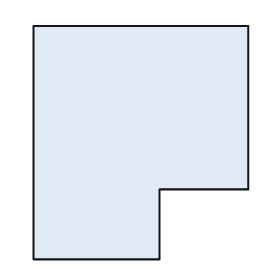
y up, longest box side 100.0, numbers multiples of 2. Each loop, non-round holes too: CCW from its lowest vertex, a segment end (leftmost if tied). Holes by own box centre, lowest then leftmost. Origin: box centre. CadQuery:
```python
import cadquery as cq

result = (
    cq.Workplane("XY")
    .moveTo(-46.0, -50.0)
    .lineTo(8.0, -50.0)
    .lineTo(8.0, -20.0)
    .lineTo(46.0, -20.0)
    .lineTo(46.0, 50.0)
    .lineTo(-46.0, 50.0)
    .close()
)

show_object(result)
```